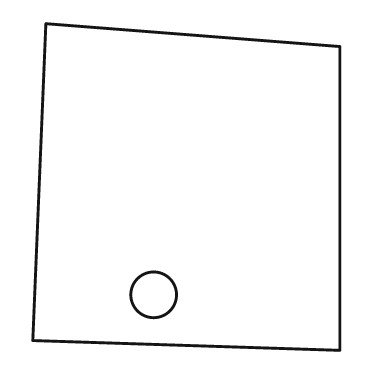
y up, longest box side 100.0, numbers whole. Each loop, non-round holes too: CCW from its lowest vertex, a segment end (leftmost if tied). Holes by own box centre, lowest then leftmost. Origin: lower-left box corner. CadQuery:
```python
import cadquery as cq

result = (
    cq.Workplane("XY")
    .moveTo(94.0, 0.0)
    .lineTo(94.0, 93.0)
    .lineTo(4.0, 100.0)
    .lineTo(0.0, 3.0)
    .close()
    .moveTo(37.0, 17.0)
    .circle(7.0)
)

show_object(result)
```